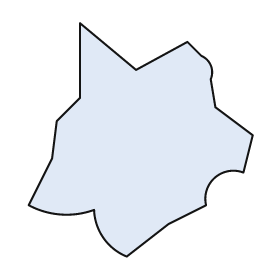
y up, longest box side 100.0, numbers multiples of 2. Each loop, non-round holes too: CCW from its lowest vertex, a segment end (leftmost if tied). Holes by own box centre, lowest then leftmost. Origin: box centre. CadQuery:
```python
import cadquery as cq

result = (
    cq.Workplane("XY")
    .moveTo(-6.0, -50.0)
    .lineTo(12.0, -36.0)
    .lineTo(28.0, -28.0)
    .threePointArc((32.0, -16.0), (44.0, -14.0))
    .lineTo(48.0, 2.0)
    .lineTo(32.0, 14.0)
    .lineTo(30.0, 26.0)
    .threePointArc((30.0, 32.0), (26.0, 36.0))
    .lineTo(20.0, 42.0)
    .lineTo(-2.0, 30.0)
    .lineTo(-26.0, 50.0)
    .lineTo(-26.0, 18.0)
    .lineTo(-36.0, 8.0)
    .lineTo(-38.0, -8.0)
    .lineTo(-48.0, -28.0)
    .threePointArc((-34.0, -32.0), (-20.0, -30.0))
    .threePointArc((-16.0, -42.0), (-6.0, -50.0))
    .close()
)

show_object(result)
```